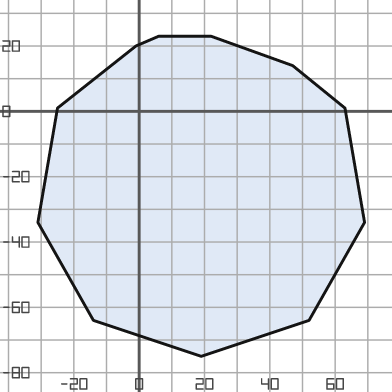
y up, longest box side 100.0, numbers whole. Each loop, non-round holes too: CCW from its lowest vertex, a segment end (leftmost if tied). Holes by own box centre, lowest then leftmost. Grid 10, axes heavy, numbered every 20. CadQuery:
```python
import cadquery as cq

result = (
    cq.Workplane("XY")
    .moveTo(19.0, -75.0)
    .lineTo(52.0, -64.0)
    .lineTo(69.0, -34.0)
    .lineTo(63.0, 1.0)
    .lineTo(47.0, 14.0)
    .lineTo(22.0, 23.0)
    .lineTo(6.0, 23.0)
    .lineTo(-1.0, 20.0)
    .lineTo(-25.0, 1.0)
    .lineTo(-31.0, -34.0)
    .lineTo(-14.0, -64.0)
    .close()
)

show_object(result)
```